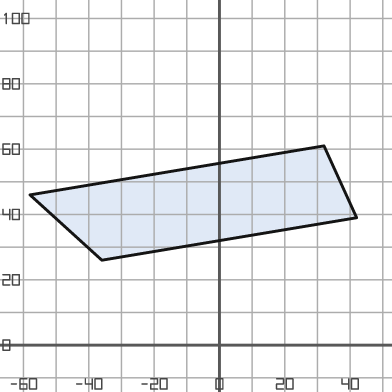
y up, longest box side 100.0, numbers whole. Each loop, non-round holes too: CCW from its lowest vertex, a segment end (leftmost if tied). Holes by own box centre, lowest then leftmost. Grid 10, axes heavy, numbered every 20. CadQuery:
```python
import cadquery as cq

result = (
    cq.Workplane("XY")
    .moveTo(-36.0, 26.0)
    .lineTo(42.0, 39.0)
    .lineTo(32.0, 61.0)
    .lineTo(-58.0, 46.0)
    .close()
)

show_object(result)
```